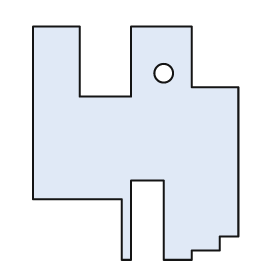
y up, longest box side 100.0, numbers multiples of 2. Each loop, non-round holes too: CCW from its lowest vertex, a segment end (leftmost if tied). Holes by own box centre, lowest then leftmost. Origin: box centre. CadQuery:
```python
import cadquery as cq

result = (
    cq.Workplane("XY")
    .moveTo(-6.0, -50.0)
    .lineTo(-2.0, -50.0)
    .lineTo(-2.0, -16.0)
    .lineTo(12.0, -16.0)
    .lineTo(12.0, -50.0)
    .lineTo(24.0, -50.0)
    .lineTo(24.0, -46.0)
    .lineTo(36.0, -46.0)
    .lineTo(36.0, -40.0)
    .lineTo(44.0, -40.0)
    .lineTo(44.0, 24.0)
    .lineTo(24.0, 24.0)
    .lineTo(24.0, 50.0)
    .lineTo(-2.0, 50.0)
    .lineTo(-2.0, 20.0)
    .lineTo(-24.0, 20.0)
    .lineTo(-24.0, 50.0)
    .lineTo(-44.0, 50.0)
    .lineTo(-44.0, -24.0)
    .lineTo(-6.0, -24.0)
    .close()
    .moveTo(12.0, 30.0)
    .circle(4.0)
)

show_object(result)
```